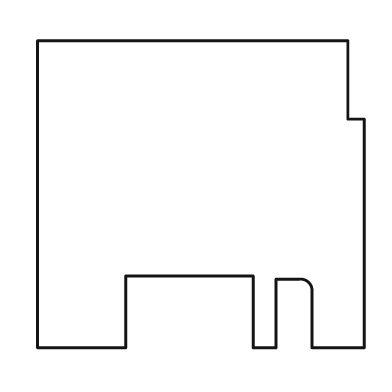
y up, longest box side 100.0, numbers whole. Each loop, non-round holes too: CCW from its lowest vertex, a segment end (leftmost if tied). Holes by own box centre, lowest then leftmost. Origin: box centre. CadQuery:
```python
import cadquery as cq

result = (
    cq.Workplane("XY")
    .moveTo(-50.0, -47.0)
    .lineTo(-23.0, -47.0)
    .lineTo(-23.0, -25.0)
    .lineTo(16.0, -25.0)
    .lineTo(16.0, -47.0)
    .lineTo(23.0, -47.0)
    .lineTo(23.0, -26.0)
    .lineTo(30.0, -26.0)
    .threePointArc((33.0, -27.0), (34.0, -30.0))
    .lineTo(34.0, -47.0)
    .lineTo(50.0, -47.0)
    .lineTo(50.0, 23.0)
    .lineTo(45.0, 23.0)
    .lineTo(45.0, 47.0)
    .lineTo(-50.0, 47.0)
    .close()
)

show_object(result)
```